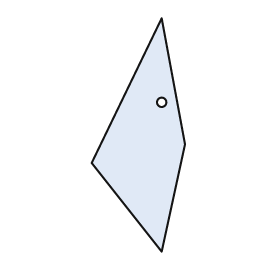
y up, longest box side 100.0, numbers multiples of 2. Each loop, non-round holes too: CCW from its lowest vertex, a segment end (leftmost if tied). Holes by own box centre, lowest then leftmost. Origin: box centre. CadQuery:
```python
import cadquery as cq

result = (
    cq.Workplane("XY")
    .moveTo(10.0, -50.0)
    .lineTo(20.0, -4.0)
    .lineTo(10.0, 50.0)
    .lineTo(-20.0, -12.0)
    .close()
    .moveTo(10.0, 14.0)
    .circle(2.0)
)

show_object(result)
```